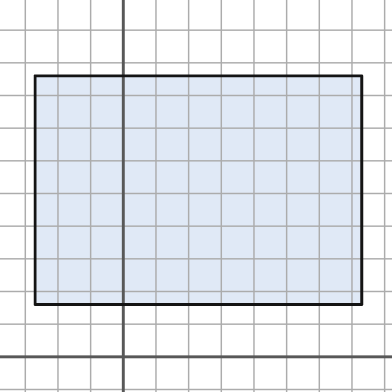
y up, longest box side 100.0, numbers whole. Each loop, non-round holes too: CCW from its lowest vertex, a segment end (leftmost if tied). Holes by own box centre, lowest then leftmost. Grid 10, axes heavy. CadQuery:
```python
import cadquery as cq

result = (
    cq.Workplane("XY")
    .moveTo(-27.0, 16.0)
    .lineTo(73.0, 16.0)
    .lineTo(73.0, 86.0)
    .lineTo(-27.0, 86.0)
    .close()
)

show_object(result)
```